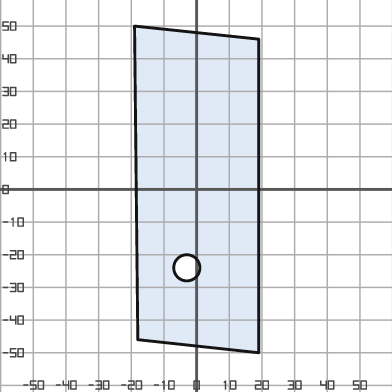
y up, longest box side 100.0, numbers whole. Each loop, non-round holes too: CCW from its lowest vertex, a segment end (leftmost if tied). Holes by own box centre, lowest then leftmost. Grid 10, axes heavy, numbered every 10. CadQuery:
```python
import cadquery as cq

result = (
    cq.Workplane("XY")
    .moveTo(19.0, -50.0)
    .lineTo(19.0, 46.0)
    .lineTo(-19.0, 50.0)
    .lineTo(-18.0, -46.0)
    .close()
    .moveTo(-3.0, -24.0)
    .circle(4.0)
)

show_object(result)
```